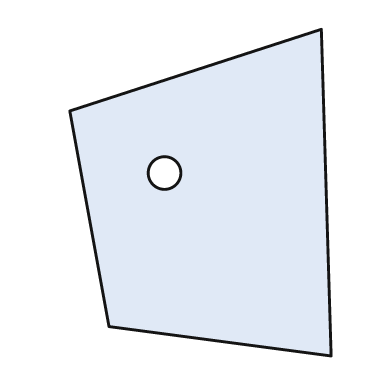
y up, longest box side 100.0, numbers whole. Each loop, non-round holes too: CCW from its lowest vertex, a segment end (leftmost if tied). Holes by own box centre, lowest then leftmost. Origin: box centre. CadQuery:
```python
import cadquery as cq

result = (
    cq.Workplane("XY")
    .moveTo(40.0, -50.0)
    .lineTo(37.0, 50.0)
    .lineTo(-40.0, 25.0)
    .lineTo(-28.0, -41.0)
    .close()
    .moveTo(-11.0, 6.0)
    .circle(5.0)
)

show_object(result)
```